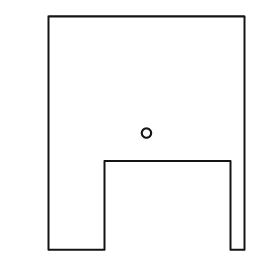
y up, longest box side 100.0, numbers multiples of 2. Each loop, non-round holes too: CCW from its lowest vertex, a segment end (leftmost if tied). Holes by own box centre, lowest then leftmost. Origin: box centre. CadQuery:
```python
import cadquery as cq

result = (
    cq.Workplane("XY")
    .moveTo(-42.0, -50.0)
    .lineTo(-18.0, -50.0)
    .lineTo(-18.0, -12.0)
    .lineTo(36.0, -12.0)
    .lineTo(36.0, -50.0)
    .lineTo(42.0, -50.0)
    .lineTo(42.0, 50.0)
    .lineTo(-42.0, 50.0)
    .close()
    .moveTo(0.0, 0.0)
    .circle(2.0)
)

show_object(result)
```